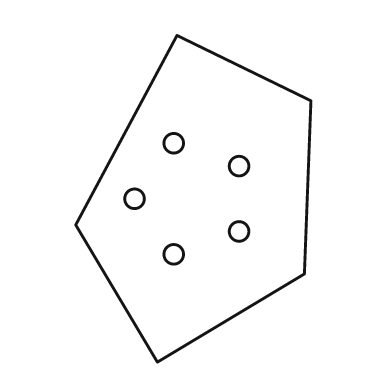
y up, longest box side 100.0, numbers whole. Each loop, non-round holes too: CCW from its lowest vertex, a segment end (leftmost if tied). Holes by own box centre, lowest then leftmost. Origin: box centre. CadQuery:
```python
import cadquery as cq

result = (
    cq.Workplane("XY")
    .moveTo(-11.0, -50.0)
    .lineTo(34.0, -23.0)
    .lineTo(36.0, 30.0)
    .lineTo(-5.0, 50.0)
    .lineTo(-36.0, -8.0)
    .close()
    .moveTo(-6.0, -17.0)
    .circle(3.0)
    .moveTo(14.0, -10.0)
    .circle(3.0)
    .moveTo(-18.0, 0.0)
    .circle(3.0)
    .moveTo(14.0, 10.0)
    .circle(3.0)
    .moveTo(-6.0, 17.0)
    .circle(3.0)
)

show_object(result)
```